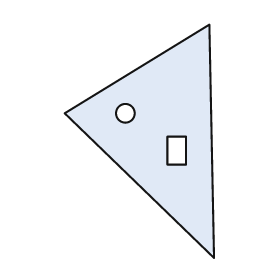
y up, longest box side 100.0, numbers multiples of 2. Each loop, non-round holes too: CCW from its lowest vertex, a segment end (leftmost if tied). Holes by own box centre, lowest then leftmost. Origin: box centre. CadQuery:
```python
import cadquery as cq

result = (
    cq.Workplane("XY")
    .moveTo(32.0, -50.0)
    .lineTo(30.0, 50.0)
    .lineTo(-32.0, 12.0)
    .close()
    .moveTo(12.0, -10.0)
    .lineTo(20.0, -10.0)
    .lineTo(20.0, 2.0)
    .lineTo(12.0, 2.0)
    .close()
    .moveTo(-6.0, 12.0)
    .circle(4.0)
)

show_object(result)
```